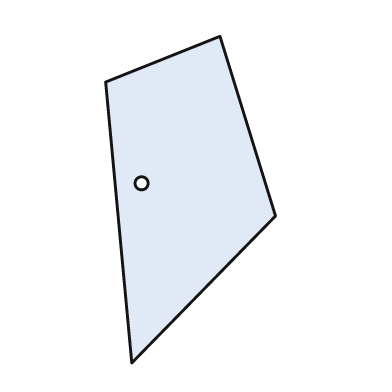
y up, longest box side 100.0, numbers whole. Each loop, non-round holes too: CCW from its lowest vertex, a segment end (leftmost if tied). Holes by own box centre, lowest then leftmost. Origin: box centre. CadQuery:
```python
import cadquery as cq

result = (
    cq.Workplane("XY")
    .moveTo(-18.0, -50.0)
    .lineTo(26.0, -5.0)
    .lineTo(9.0, 50.0)
    .lineTo(-26.0, 36.0)
    .close()
    .moveTo(-15.0, 5.0)
    .circle(2.0)
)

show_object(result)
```